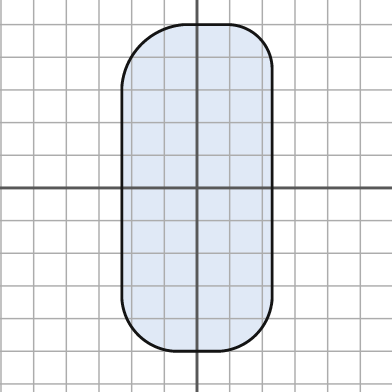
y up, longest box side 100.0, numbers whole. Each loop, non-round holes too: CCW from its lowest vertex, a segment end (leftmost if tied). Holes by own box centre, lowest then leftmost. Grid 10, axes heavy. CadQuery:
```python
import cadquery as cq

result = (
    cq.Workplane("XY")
    .moveTo(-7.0, -50.0)
    .lineTo(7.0, -50.0)
    .threePointArc((18.0, -45.0), (23.0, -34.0))
    .lineTo(23.0, 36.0)
    .threePointArc((19.0, 46.0), (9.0, 50.0))
    .lineTo(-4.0, 50.0)
    .threePointArc((-17.0, 44.0), (-23.0, 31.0))
    .lineTo(-23.0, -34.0)
    .threePointArc((-18.0, -45.0), (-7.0, -50.0))
    .close()
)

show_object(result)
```